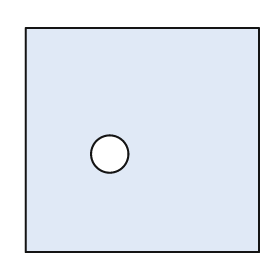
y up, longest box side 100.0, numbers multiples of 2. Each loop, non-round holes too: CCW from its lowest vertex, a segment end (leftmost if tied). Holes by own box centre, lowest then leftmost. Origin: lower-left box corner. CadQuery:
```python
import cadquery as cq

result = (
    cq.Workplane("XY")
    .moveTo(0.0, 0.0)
    .lineTo(100.0, 0.0)
    .lineTo(100.0, 96.0)
    .lineTo(0.0, 96.0)
    .close()
    .moveTo(36.0, 42.0)
    .circle(8.0)
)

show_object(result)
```